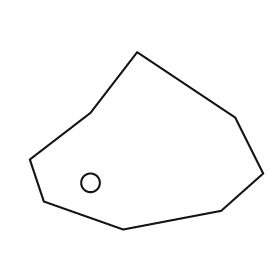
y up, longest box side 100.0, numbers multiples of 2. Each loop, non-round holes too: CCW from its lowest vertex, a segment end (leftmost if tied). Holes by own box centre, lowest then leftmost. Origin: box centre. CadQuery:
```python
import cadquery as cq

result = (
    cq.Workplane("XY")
    .moveTo(-10.0, -38.0)
    .lineTo(32.0, -30.0)
    .lineTo(50.0, -14.0)
    .lineTo(38.0, 10.0)
    .lineTo(-4.0, 38.0)
    .lineTo(-24.0, 12.0)
    .lineTo(-50.0, -8.0)
    .lineTo(-44.0, -26.0)
    .close()
    .moveTo(-24.0, -18.0)
    .circle(4.0)
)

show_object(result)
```